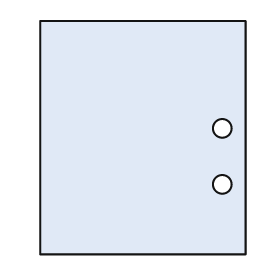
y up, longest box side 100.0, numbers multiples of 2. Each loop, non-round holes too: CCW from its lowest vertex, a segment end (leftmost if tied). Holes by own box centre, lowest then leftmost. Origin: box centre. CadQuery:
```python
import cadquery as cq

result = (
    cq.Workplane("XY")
    .moveTo(-44.0, -50.0)
    .lineTo(44.0, -50.0)
    .lineTo(44.0, 50.0)
    .lineTo(-44.0, 50.0)
    .close()
    .moveTo(34.0, -20.0)
    .circle(4.0)
    .moveTo(34.0, 4.0)
    .circle(4.0)
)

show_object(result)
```